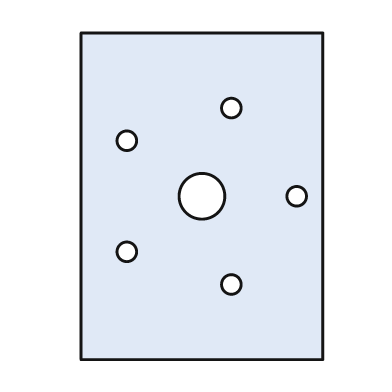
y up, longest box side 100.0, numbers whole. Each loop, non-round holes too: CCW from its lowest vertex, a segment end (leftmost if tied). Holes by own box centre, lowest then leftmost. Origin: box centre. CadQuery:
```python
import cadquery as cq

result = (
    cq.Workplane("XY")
    .moveTo(-37.0, -50.0)
    .lineTo(37.0, -50.0)
    .lineTo(37.0, 50.0)
    .lineTo(-37.0, 50.0)
    .close()
    .moveTo(9.0, -27.0)
    .circle(3.0)
    .moveTo(-23.0, -17.0)
    .circle(3.0)
    .moveTo(0.0, 0.0)
    .circle(7.0)
    .moveTo(29.0, 0.0)
    .circle(3.0)
    .moveTo(-23.0, 17.0)
    .circle(3.0)
    .moveTo(9.0, 27.0)
    .circle(3.0)
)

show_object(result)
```